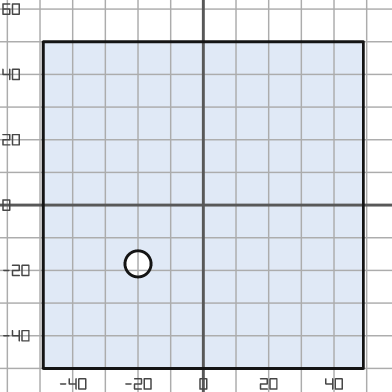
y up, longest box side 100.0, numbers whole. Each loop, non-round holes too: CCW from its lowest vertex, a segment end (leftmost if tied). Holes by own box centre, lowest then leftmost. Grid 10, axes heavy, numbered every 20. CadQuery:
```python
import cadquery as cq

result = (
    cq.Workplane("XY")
    .moveTo(-49.0, -50.0)
    .lineTo(49.0, -50.0)
    .lineTo(49.0, 50.0)
    .lineTo(-49.0, 50.0)
    .close()
    .moveTo(-20.0, -18.0)
    .circle(4.0)
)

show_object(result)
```